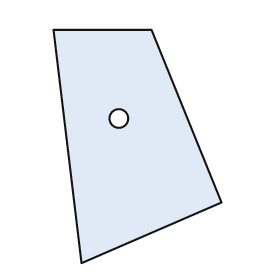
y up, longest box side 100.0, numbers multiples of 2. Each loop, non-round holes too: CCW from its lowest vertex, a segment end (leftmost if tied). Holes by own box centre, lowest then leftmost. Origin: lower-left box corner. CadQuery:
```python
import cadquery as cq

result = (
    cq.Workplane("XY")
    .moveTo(12.0, 0.0)
    .lineTo(72.0, 26.0)
    .lineTo(42.0, 100.0)
    .lineTo(0.0, 100.0)
    .close()
    .moveTo(28.0, 62.0)
    .circle(4.0)
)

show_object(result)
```